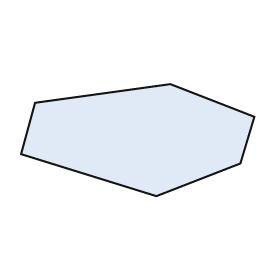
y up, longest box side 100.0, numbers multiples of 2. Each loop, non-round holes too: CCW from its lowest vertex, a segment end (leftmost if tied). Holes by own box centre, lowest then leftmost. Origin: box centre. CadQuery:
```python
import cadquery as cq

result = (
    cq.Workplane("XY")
    .moveTo(8.0, -24.0)
    .lineTo(44.0, -10.0)
    .lineTo(50.0, 10.0)
    .lineTo(14.0, 24.0)
    .lineTo(-44.0, 16.0)
    .lineTo(-50.0, -6.0)
    .close()
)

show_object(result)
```